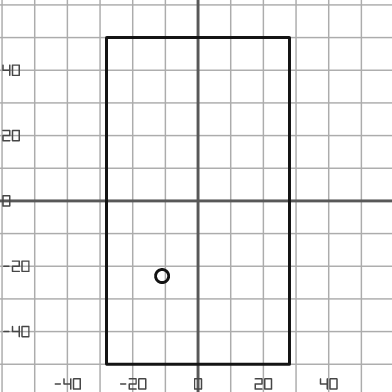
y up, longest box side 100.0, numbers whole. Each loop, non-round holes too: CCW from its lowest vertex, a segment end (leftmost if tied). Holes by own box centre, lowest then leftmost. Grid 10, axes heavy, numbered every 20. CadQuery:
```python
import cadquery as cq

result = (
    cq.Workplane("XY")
    .moveTo(-28.0, -50.0)
    .lineTo(28.0, -50.0)
    .lineTo(28.0, 50.0)
    .lineTo(-28.0, 50.0)
    .close()
    .moveTo(-11.0, -23.0)
    .circle(2.0)
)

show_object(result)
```